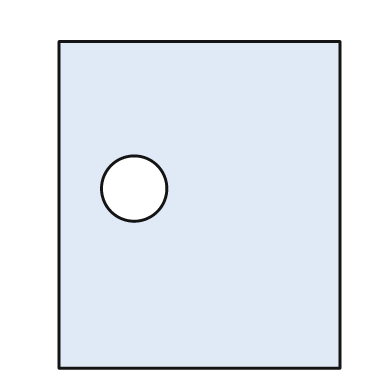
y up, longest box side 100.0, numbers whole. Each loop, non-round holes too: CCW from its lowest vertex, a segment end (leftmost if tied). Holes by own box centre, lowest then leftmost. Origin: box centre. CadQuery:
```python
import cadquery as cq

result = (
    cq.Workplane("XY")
    .moveTo(-43.0, -50.0)
    .lineTo(43.0, -50.0)
    .lineTo(43.0, 50.0)
    .lineTo(-43.0, 50.0)
    .close()
    .moveTo(-20.0, 5.0)
    .circle(10.0)
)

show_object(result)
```